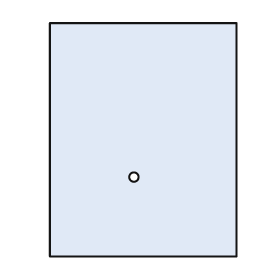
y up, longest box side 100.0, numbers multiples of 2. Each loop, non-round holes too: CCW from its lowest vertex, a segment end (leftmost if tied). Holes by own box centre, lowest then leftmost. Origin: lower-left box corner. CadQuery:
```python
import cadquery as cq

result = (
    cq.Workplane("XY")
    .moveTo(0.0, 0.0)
    .lineTo(80.0, 0.0)
    .lineTo(80.0, 100.0)
    .lineTo(0.0, 100.0)
    .close()
    .moveTo(36.0, 34.0)
    .circle(2.0)
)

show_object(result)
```